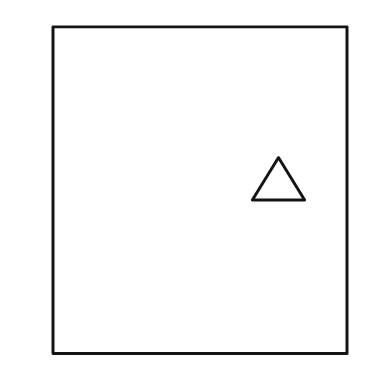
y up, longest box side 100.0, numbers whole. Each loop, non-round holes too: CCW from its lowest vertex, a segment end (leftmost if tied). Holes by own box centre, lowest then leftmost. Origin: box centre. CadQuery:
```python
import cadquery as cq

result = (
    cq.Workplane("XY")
    .moveTo(-45.0, -50.0)
    .lineTo(45.0, -50.0)
    .lineTo(45.0, 50.0)
    .lineTo(-45.0, 50.0)
    .close()
    .moveTo(16.0, -3.0)
    .lineTo(32.0, -3.0)
    .lineTo(24.0, 10.0)
    .close()
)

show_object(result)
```